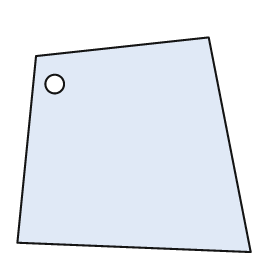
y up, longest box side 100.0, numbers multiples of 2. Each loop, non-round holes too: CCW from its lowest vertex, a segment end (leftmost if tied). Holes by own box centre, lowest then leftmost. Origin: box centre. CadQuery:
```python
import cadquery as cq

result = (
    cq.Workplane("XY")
    .moveTo(50.0, -46.0)
    .lineTo(32.0, 46.0)
    .lineTo(-42.0, 38.0)
    .lineTo(-50.0, -42.0)
    .close()
    .moveTo(-34.0, 26.0)
    .circle(4.0)
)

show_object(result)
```